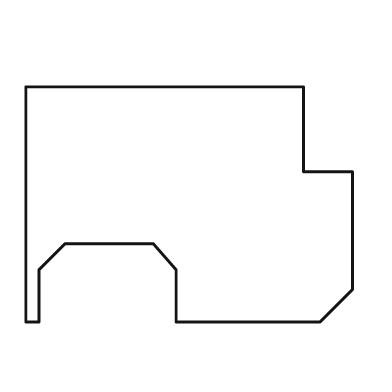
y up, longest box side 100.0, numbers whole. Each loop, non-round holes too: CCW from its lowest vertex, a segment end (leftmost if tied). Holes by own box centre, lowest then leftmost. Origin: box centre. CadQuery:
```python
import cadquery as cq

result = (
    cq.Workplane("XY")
    .moveTo(-50.0, -36.0)
    .lineTo(-46.0, -36.0)
    .lineTo(-46.0, -20.0)
    .lineTo(-38.0, -12.0)
    .lineTo(-11.0, -12.0)
    .lineTo(-4.0, -20.0)
    .lineTo(-4.0, -36.0)
    .lineTo(40.0, -36.0)
    .lineTo(50.0, -26.0)
    .lineTo(50.0, 10.0)
    .lineTo(35.0, 10.0)
    .lineTo(35.0, 36.0)
    .lineTo(-50.0, 36.0)
    .close()
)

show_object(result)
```